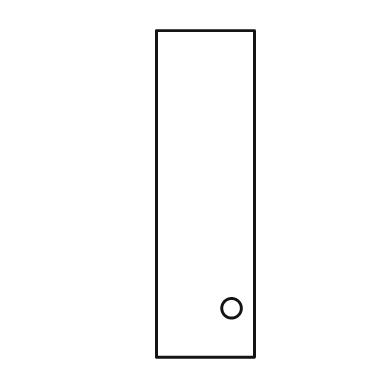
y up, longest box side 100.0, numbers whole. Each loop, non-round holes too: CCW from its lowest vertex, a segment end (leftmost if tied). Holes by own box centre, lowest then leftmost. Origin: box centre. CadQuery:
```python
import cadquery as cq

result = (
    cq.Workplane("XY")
    .moveTo(-15.0, -50.0)
    .lineTo(15.0, -50.0)
    .lineTo(15.0, 50.0)
    .lineTo(-15.0, 50.0)
    .close()
    .moveTo(8.0, -35.0)
    .circle(3.0)
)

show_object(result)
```